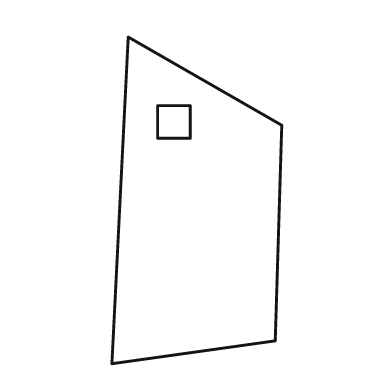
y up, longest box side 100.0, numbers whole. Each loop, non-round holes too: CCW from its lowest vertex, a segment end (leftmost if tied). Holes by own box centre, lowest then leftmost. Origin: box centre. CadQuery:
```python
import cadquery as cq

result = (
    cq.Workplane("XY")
    .moveTo(-26.0, -50.0)
    .lineTo(24.0, -43.0)
    .lineTo(26.0, 23.0)
    .lineTo(-21.0, 50.0)
    .close()
    .moveTo(-12.0, 19.0)
    .lineTo(-2.0, 19.0)
    .lineTo(-2.0, 29.0)
    .lineTo(-12.0, 29.0)
    .close()
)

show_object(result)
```